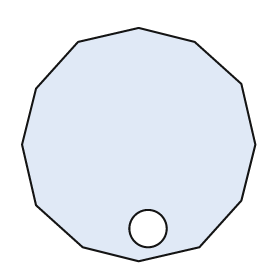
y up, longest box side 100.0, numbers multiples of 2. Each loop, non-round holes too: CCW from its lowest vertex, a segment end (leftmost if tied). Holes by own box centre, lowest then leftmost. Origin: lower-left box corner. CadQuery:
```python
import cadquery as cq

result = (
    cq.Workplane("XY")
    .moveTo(50.0, 0.0)
    .lineTo(76.0, 6.0)
    .lineTo(94.0, 26.0)
    .lineTo(100.0, 50.0)
    .lineTo(94.0, 76.0)
    .lineTo(74.0, 94.0)
    .lineTo(50.0, 100.0)
    .lineTo(24.0, 94.0)
    .lineTo(6.0, 74.0)
    .lineTo(0.0, 50.0)
    .lineTo(6.0, 24.0)
    .lineTo(26.0, 6.0)
    .close()
    .moveTo(54.0, 14.0)
    .circle(8.0)
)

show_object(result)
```